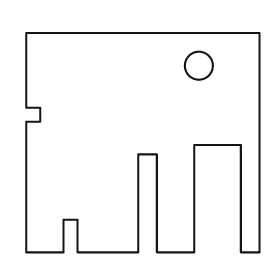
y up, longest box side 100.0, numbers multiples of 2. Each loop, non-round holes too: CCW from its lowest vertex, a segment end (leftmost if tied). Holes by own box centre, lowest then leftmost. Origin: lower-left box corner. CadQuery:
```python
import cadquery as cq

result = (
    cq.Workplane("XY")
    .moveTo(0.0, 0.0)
    .lineTo(16.0, 0.0)
    .lineTo(16.0, 14.0)
    .lineTo(22.0, 14.0)
    .lineTo(22.0, 0.0)
    .lineTo(48.0, 0.0)
    .lineTo(48.0, 42.0)
    .lineTo(56.0, 42.0)
    .lineTo(56.0, 0.0)
    .lineTo(72.0, 0.0)
    .lineTo(72.0, 46.0)
    .lineTo(92.0, 46.0)
    .lineTo(92.0, 0.0)
    .lineTo(100.0, 0.0)
    .lineTo(100.0, 94.0)
    .lineTo(0.0, 94.0)
    .lineTo(0.0, 62.0)
    .lineTo(6.0, 62.0)
    .lineTo(6.0, 56.0)
    .lineTo(0.0, 56.0)
    .close()
    .moveTo(74.0, 80.0)
    .circle(6.0)
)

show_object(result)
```